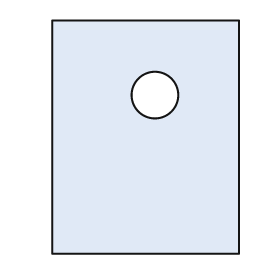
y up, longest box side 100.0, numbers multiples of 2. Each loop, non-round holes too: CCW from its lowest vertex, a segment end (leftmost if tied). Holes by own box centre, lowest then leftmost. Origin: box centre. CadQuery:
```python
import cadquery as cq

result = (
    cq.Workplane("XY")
    .moveTo(-40.0, -50.0)
    .lineTo(40.0, -50.0)
    .lineTo(40.0, 50.0)
    .lineTo(-40.0, 50.0)
    .close()
    .moveTo(4.0, 18.0)
    .circle(10.0)
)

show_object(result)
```